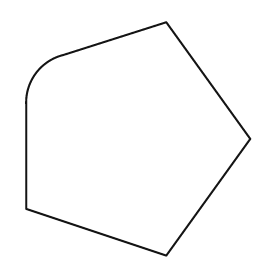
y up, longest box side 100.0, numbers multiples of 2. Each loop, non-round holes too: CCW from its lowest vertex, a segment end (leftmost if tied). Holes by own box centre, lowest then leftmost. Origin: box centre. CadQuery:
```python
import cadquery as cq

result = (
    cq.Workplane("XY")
    .moveTo(12.0, -50.0)
    .lineTo(48.0, 0.0)
    .lineTo(12.0, 50.0)
    .lineTo(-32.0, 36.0)
    .threePointArc((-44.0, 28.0), (-48.0, 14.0))
    .lineTo(-48.0, -30.0)
    .close()
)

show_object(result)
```